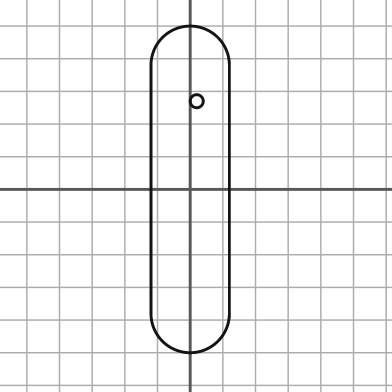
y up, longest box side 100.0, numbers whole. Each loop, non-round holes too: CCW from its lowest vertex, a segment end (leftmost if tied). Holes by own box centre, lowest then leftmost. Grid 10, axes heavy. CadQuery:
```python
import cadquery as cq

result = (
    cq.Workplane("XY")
    .moveTo(-12.0, -38.0)
    .threePointArc((0.0, -50.0), (12.0, -38.0))
    .lineTo(12.0, 38.0)
    .threePointArc((0.0, 50.0), (-12.0, 38.0))
    .close()
    .moveTo(2.0, 27.0)
    .circle(2.0)
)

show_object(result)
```